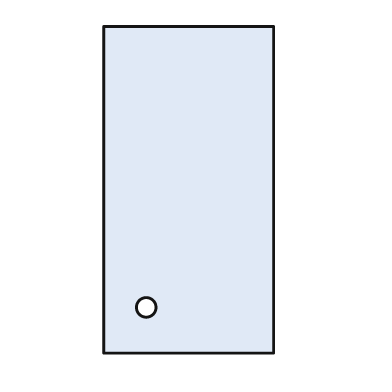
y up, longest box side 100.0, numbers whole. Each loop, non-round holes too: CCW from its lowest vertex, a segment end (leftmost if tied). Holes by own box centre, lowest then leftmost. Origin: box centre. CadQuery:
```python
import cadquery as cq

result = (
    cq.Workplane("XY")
    .moveTo(-26.0, -50.0)
    .lineTo(26.0, -50.0)
    .lineTo(26.0, 50.0)
    .lineTo(-26.0, 50.0)
    .close()
    .moveTo(-13.0, -36.0)
    .circle(3.0)
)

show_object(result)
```